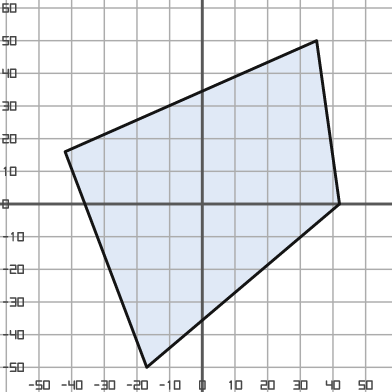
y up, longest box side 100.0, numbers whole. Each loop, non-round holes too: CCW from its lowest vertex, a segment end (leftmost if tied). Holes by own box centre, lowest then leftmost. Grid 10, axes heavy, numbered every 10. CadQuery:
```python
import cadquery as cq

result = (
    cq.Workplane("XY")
    .moveTo(-17.0, -50.0)
    .lineTo(42.0, 0.0)
    .lineTo(35.0, 50.0)
    .lineTo(-42.0, 16.0)
    .close()
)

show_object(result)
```